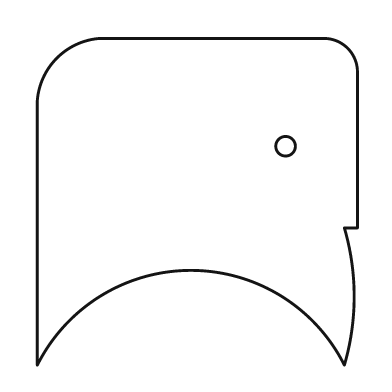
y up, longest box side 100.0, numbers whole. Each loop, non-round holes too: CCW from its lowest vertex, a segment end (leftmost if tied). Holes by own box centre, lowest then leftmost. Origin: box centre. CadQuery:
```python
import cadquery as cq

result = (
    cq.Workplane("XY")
    .moveTo(-49.0, -50.0)
    .threePointArc((-2.0, -21.0), (45.0, -50.0))
    .threePointArc((48.0, -29.0), (45.0, -8.0))
    .lineTo(49.0, -8.0)
    .lineTo(49.0, 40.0)
    .threePointArc((46.0, 47.0), (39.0, 50.0))
    .lineTo(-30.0, 50.0)
    .threePointArc((-43.0, 44.0), (-49.0, 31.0))
    .close()
    .moveTo(27.0, 17.0)
    .circle(3.0)
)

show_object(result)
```